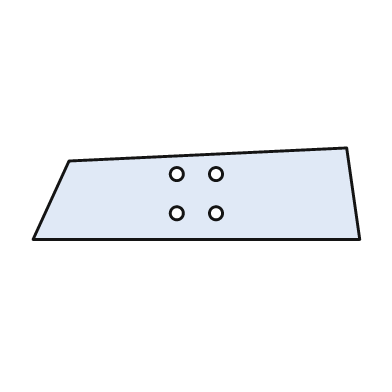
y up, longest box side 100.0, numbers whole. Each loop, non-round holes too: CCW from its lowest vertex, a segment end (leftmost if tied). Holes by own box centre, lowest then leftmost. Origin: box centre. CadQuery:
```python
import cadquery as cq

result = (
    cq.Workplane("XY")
    .moveTo(-50.0, -14.0)
    .lineTo(50.0, -14.0)
    .lineTo(46.0, 14.0)
    .lineTo(-39.0, 10.0)
    .close()
    .moveTo(-6.0, -6.0)
    .circle(2.0)
    .moveTo(6.0, -6.0)
    .circle(2.0)
    .moveTo(-6.0, 6.0)
    .circle(2.0)
    .moveTo(6.0, 6.0)
    .circle(2.0)
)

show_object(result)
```